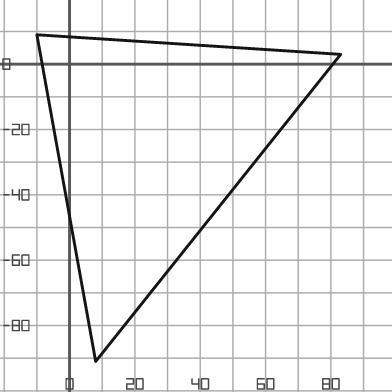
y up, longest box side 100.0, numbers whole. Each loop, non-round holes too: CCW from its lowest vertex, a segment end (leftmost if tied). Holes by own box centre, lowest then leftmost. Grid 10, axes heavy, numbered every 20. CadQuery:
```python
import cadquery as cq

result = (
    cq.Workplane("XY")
    .moveTo(8.0, -91.0)
    .lineTo(83.0, 3.0)
    .lineTo(-10.0, 9.0)
    .close()
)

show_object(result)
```